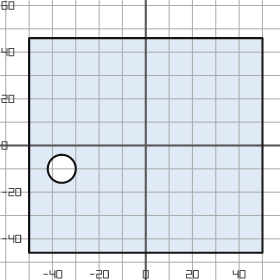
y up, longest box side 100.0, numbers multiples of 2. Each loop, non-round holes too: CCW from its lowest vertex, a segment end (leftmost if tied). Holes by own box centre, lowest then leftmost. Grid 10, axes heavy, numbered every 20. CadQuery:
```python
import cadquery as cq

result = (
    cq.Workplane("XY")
    .moveTo(-50.0, -46.0)
    .lineTo(50.0, -46.0)
    .lineTo(50.0, 46.0)
    .lineTo(-50.0, 46.0)
    .close()
    .moveTo(-36.0, -10.0)
    .circle(6.0)
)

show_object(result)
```